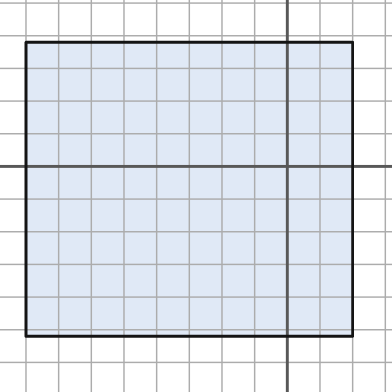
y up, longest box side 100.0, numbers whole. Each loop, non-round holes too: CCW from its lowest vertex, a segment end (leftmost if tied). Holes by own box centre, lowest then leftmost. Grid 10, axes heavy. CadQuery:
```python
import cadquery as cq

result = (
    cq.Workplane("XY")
    .moveTo(-80.0, -52.0)
    .lineTo(20.0, -52.0)
    .lineTo(20.0, 38.0)
    .lineTo(-80.0, 38.0)
    .close()
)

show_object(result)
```